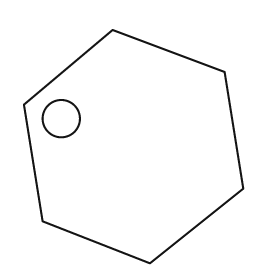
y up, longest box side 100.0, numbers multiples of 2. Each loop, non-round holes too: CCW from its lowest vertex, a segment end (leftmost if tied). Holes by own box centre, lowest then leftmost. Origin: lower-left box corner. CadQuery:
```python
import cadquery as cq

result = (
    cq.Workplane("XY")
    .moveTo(54.0, 0.0)
    .lineTo(94.0, 32.0)
    .lineTo(86.0, 82.0)
    .lineTo(38.0, 100.0)
    .lineTo(0.0, 68.0)
    .lineTo(8.0, 18.0)
    .close()
    .moveTo(16.0, 62.0)
    .circle(8.0)
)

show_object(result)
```